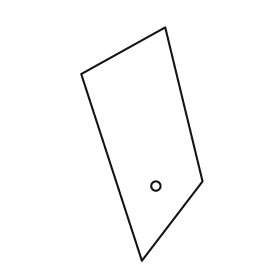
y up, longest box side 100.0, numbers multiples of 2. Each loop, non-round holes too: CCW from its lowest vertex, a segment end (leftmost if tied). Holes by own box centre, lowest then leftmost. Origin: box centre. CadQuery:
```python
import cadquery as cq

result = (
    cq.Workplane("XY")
    .moveTo(0.0, -50.0)
    .lineTo(26.0, -16.0)
    .lineTo(10.0, 50.0)
    .lineTo(-26.0, 30.0)
    .close()
    .moveTo(6.0, -18.0)
    .circle(2.0)
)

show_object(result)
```